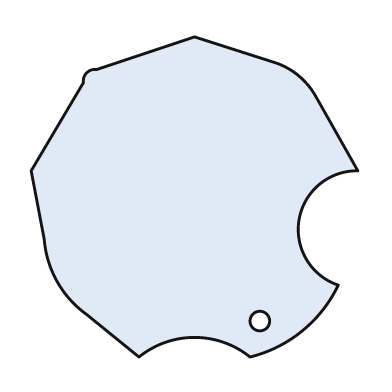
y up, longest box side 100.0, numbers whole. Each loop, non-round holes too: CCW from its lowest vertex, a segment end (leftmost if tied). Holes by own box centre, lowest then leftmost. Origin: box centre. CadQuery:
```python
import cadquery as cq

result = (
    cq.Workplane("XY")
    .moveTo(-17.0, -49.0)
    .threePointArc((0.0, -43.0), (17.0, -49.0))
    .threePointArc((33.0, -41.0), (44.0, -27.0))
    .threePointArc((32.0, -7.0), (50.0, 8.0))
    .lineTo(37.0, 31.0)
    .threePointArc((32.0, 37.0), (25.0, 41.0))
    .lineTo(0.0, 49.0)
    .lineTo(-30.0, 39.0)
    .threePointArc((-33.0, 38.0), (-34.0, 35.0))
    .lineTo(-50.0, 8.0)
    .lineTo(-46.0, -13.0)
    .threePointArc((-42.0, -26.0), (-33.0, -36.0))
    .close()
    .moveTo(20.0, -38.0)
    .circle(3.0)
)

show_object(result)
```